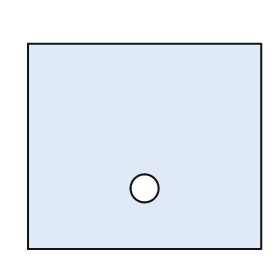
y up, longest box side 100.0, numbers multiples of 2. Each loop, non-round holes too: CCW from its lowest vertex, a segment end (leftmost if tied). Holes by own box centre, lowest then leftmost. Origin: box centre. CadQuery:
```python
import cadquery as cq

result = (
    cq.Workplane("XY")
    .moveTo(-50.0, -44.0)
    .lineTo(50.0, -44.0)
    .lineTo(50.0, 44.0)
    .lineTo(-50.0, 44.0)
    .close()
    .moveTo(0.0, -18.0)
    .circle(6.0)
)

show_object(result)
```